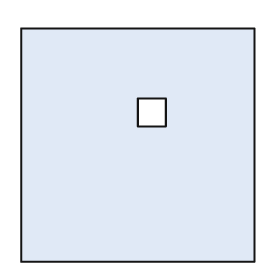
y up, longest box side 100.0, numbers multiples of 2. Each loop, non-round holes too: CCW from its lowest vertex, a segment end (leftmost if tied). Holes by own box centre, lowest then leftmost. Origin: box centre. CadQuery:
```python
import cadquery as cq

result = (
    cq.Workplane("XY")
    .moveTo(-50.0, -50.0)
    .lineTo(50.0, -50.0)
    .lineTo(50.0, 50.0)
    .lineTo(-50.0, 50.0)
    .close()
    .moveTo(0.0, 8.0)
    .lineTo(12.0, 8.0)
    .lineTo(12.0, 20.0)
    .lineTo(0.0, 20.0)
    .close()
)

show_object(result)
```